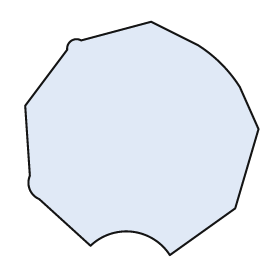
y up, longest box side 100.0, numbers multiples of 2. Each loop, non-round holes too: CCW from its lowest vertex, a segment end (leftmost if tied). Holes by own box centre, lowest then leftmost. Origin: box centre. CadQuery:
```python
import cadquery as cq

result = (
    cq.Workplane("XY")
    .moveTo(12.0, -50.0)
    .lineTo(40.0, -30.0)
    .lineTo(50.0, 4.0)
    .lineTo(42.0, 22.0)
    .threePointArc((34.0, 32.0), (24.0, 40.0))
    .lineTo(4.0, 50.0)
    .lineTo(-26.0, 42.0)
    .threePointArc((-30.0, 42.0), (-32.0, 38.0))
    .lineTo(-50.0, 14.0)
    .lineTo(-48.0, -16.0)
    .threePointArc((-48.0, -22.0), (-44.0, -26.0))
    .lineTo(-22.0, -46.0)
    .threePointArc((-4.0, -40.0), (12.0, -50.0))
    .close()
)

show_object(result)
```